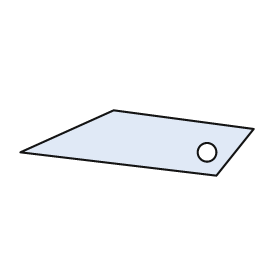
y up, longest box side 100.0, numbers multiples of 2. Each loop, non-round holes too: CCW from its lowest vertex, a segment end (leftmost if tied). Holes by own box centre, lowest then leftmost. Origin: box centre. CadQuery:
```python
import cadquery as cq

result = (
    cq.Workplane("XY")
    .moveTo(34.0, -14.0)
    .lineTo(50.0, 6.0)
    .lineTo(-10.0, 14.0)
    .lineTo(-50.0, -4.0)
    .close()
    .moveTo(30.0, -4.0)
    .circle(4.0)
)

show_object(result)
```